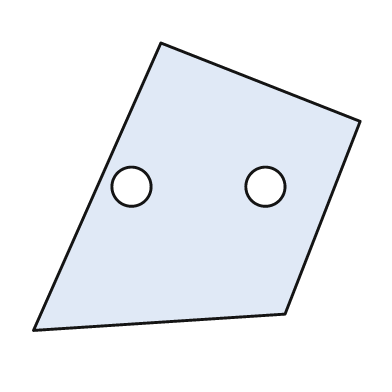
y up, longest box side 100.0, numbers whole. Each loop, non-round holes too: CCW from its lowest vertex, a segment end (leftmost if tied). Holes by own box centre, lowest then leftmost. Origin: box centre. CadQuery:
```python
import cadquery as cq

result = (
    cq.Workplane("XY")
    .moveTo(-50.0, -44.0)
    .lineTo(27.0, -39.0)
    .lineTo(50.0, 20.0)
    .lineTo(-11.0, 44.0)
    .close()
    .moveTo(-20.0, 0.0)
    .circle(6.0)
    .moveTo(21.0, 0.0)
    .circle(6.0)
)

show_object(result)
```